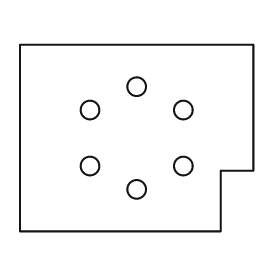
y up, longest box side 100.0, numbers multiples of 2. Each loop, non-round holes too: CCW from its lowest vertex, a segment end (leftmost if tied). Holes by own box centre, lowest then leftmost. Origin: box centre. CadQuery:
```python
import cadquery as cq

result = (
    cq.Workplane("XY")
    .moveTo(-50.0, -40.0)
    .lineTo(36.0, -40.0)
    .lineTo(36.0, -14.0)
    .lineTo(50.0, -14.0)
    .lineTo(50.0, 40.0)
    .lineTo(-50.0, 40.0)
    .close()
    .moveTo(0.0, -22.0)
    .circle(4.0)
    .moveTo(-20.0, -12.0)
    .circle(4.0)
    .moveTo(20.0, -12.0)
    .circle(4.0)
    .moveTo(-20.0, 12.0)
    .circle(4.0)
    .moveTo(20.0, 12.0)
    .circle(4.0)
    .moveTo(0.0, 22.0)
    .circle(4.0)
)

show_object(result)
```